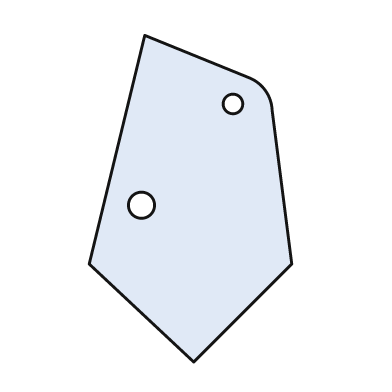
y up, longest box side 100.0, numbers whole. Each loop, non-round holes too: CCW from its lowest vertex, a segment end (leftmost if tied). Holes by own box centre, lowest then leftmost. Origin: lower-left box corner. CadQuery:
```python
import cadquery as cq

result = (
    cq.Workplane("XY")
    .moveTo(32.0, 0.0)
    .lineTo(62.0, 30.0)
    .lineTo(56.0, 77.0)
    .threePointArc((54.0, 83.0), (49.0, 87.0))
    .lineTo(17.0, 100.0)
    .lineTo(0.0, 30.0)
    .close()
    .moveTo(16.0, 48.0)
    .circle(4.0)
    .moveTo(44.0, 79.0)
    .circle(3.0)
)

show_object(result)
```